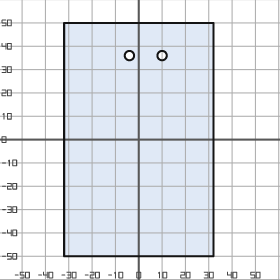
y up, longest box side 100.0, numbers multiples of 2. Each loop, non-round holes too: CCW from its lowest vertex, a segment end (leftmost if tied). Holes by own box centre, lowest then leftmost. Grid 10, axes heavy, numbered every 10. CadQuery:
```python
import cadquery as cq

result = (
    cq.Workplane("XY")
    .moveTo(-32.0, -50.0)
    .lineTo(32.0, -50.0)
    .lineTo(32.0, 50.0)
    .lineTo(-32.0, 50.0)
    .close()
    .moveTo(-4.0, 36.0)
    .circle(2.0)
    .moveTo(10.0, 36.0)
    .circle(2.0)
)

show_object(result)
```